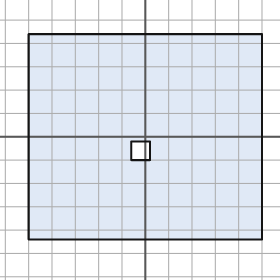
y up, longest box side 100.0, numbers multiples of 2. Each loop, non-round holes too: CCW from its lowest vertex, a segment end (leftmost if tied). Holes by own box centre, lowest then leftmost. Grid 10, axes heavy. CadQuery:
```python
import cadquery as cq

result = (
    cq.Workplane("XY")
    .moveTo(-50.0, -44.0)
    .lineTo(50.0, -44.0)
    .lineTo(50.0, 44.0)
    .lineTo(-50.0, 44.0)
    .close()
    .moveTo(-6.0, -10.0)
    .lineTo(2.0, -10.0)
    .lineTo(2.0, -2.0)
    .lineTo(-6.0, -2.0)
    .close()
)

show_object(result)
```